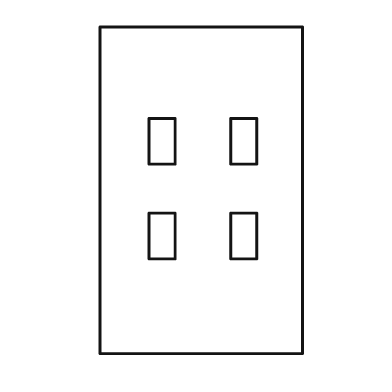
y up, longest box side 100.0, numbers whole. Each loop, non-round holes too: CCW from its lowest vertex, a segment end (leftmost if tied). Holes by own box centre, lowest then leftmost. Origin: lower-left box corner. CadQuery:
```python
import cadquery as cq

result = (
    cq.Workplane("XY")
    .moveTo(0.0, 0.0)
    .lineTo(62.0, 0.0)
    .lineTo(62.0, 100.0)
    .lineTo(0.0, 100.0)
    .close()
    .moveTo(15.0, 29.0)
    .lineTo(23.0, 29.0)
    .lineTo(23.0, 43.0)
    .lineTo(15.0, 43.0)
    .close()
    .moveTo(40.0, 29.0)
    .lineTo(48.0, 29.0)
    .lineTo(48.0, 43.0)
    .lineTo(40.0, 43.0)
    .close()
    .moveTo(15.0, 58.0)
    .lineTo(23.0, 58.0)
    .lineTo(23.0, 72.0)
    .lineTo(15.0, 72.0)
    .close()
    .moveTo(40.0, 58.0)
    .lineTo(48.0, 58.0)
    .lineTo(48.0, 72.0)
    .lineTo(40.0, 72.0)
    .close()
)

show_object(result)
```